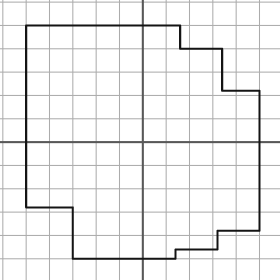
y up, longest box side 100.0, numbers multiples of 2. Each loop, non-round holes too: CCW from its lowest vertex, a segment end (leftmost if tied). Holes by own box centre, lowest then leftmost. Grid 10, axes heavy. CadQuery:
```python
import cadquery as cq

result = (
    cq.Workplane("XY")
    .moveTo(-30.0, -50.0)
    .lineTo(14.0, -50.0)
    .lineTo(14.0, -46.0)
    .lineTo(32.0, -46.0)
    .lineTo(32.0, -38.0)
    .lineTo(50.0, -38.0)
    .lineTo(50.0, 22.0)
    .lineTo(34.0, 22.0)
    .lineTo(34.0, 40.0)
    .lineTo(16.0, 40.0)
    .lineTo(16.0, 50.0)
    .lineTo(-50.0, 50.0)
    .lineTo(-50.0, -28.0)
    .lineTo(-30.0, -28.0)
    .close()
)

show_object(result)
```